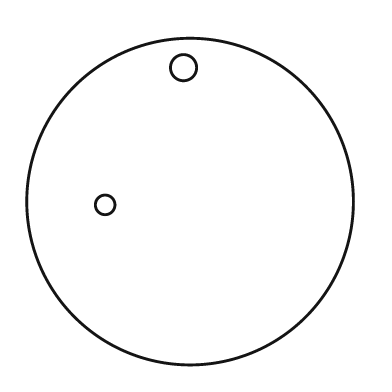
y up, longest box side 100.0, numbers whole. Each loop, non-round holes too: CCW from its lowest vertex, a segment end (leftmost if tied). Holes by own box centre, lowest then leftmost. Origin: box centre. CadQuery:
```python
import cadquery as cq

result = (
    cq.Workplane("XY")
    .moveTo(0.0, 0.0)
    .circle(50.0)
    .moveTo(-26.0, -1.0)
    .circle(3.0)
    .moveTo(-2.0, 41.0)
    .circle(4.0)
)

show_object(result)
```